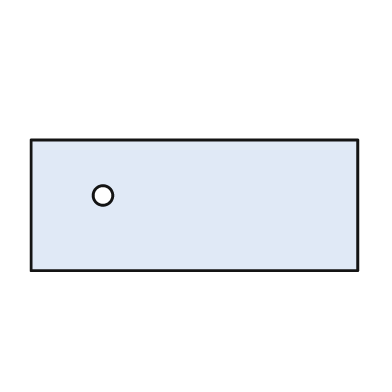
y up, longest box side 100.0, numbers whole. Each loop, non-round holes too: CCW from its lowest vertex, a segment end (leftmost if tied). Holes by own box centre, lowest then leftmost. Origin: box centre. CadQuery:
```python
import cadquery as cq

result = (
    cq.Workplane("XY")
    .moveTo(-50.0, -20.0)
    .lineTo(50.0, -20.0)
    .lineTo(50.0, 20.0)
    .lineTo(-50.0, 20.0)
    .close()
    .moveTo(-28.0, 3.0)
    .circle(3.0)
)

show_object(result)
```